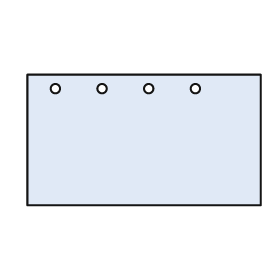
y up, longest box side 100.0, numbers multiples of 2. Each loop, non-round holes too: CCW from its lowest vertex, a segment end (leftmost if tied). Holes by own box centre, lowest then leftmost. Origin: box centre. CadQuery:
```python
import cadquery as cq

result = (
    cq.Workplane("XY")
    .moveTo(-50.0, -28.0)
    .lineTo(50.0, -28.0)
    .lineTo(50.0, 28.0)
    .lineTo(-50.0, 28.0)
    .close()
    .moveTo(-38.0, 22.0)
    .circle(2.0)
    .moveTo(-18.0, 22.0)
    .circle(2.0)
    .moveTo(2.0, 22.0)
    .circle(2.0)
    .moveTo(22.0, 22.0)
    .circle(2.0)
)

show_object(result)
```